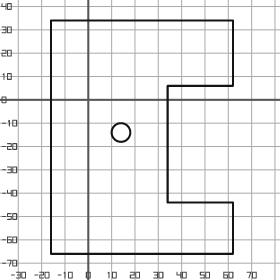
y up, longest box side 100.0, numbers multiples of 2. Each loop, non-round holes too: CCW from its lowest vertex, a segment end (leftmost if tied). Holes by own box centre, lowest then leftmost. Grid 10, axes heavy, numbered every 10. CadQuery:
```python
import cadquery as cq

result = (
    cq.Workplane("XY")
    .moveTo(-16.0, -66.0)
    .lineTo(62.0, -66.0)
    .lineTo(62.0, -44.0)
    .lineTo(34.0, -44.0)
    .lineTo(34.0, 6.0)
    .lineTo(62.0, 6.0)
    .lineTo(62.0, 34.0)
    .lineTo(-16.0, 34.0)
    .close()
    .moveTo(14.0, -14.0)
    .circle(4.0)
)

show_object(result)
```